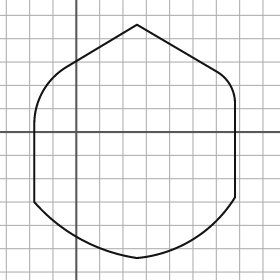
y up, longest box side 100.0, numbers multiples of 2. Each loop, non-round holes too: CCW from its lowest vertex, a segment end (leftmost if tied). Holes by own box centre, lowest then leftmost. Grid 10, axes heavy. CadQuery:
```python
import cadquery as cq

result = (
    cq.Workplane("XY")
    .moveTo(26.0, -54.0)
    .threePointArc((50.0, -46.0), (68.0, -28.0))
    .lineTo(68.0, 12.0)
    .threePointArc((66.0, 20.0), (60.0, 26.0))
    .lineTo(26.0, 46.0)
    .lineTo(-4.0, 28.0)
    .threePointArc((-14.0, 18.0), (-18.0, 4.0))
    .lineTo(-18.0, -30.0)
    .threePointArc((2.0, -46.0), (26.0, -54.0))
    .close()
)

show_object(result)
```